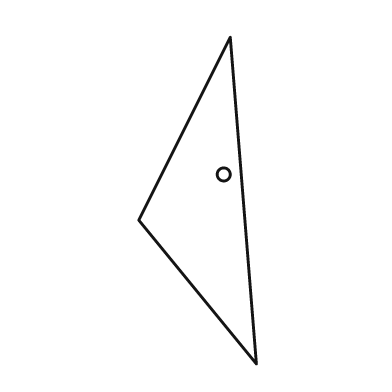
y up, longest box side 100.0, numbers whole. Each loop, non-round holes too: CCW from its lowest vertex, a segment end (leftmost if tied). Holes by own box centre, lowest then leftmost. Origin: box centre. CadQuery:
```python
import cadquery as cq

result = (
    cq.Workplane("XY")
    .moveTo(18.0, -50.0)
    .lineTo(10.0, 50.0)
    .lineTo(-18.0, -6.0)
    .close()
    .moveTo(8.0, 8.0)
    .circle(2.0)
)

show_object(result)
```